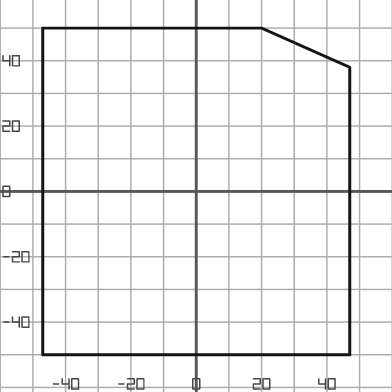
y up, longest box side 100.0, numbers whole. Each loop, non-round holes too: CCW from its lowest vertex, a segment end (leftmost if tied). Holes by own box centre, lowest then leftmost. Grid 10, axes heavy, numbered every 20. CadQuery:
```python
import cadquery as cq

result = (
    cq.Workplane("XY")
    .moveTo(-47.0, -50.0)
    .lineTo(47.0, -50.0)
    .lineTo(47.0, 38.0)
    .lineTo(20.0, 50.0)
    .lineTo(-47.0, 50.0)
    .close()
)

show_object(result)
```